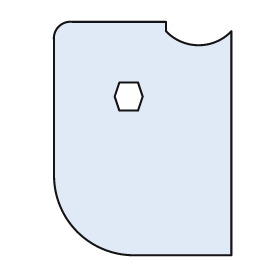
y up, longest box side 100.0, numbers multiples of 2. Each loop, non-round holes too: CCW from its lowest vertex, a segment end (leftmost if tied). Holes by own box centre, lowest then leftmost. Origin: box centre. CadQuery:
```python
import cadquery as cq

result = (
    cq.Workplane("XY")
    .moveTo(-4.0, -50.0)
    .lineTo(38.0, -50.0)
    .lineTo(38.0, 46.0)
    .threePointArc((24.0, 40.0), (10.0, 46.0))
    .lineTo(10.0, 50.0)
    .lineTo(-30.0, 50.0)
    .threePointArc((-36.0, 48.0), (-38.0, 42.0))
    .lineTo(-38.0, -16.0)
    .threePointArc((-28.0, -40.0), (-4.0, -50.0))
    .close()
    .moveTo(-10.0, 12.0)
    .lineTo(-2.0, 12.0)
    .lineTo(0.0, 18.0)
    .lineTo(-2.0, 24.0)
    .lineTo(-10.0, 24.0)
    .lineTo(-12.0, 18.0)
    .close()
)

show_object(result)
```